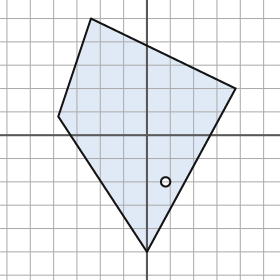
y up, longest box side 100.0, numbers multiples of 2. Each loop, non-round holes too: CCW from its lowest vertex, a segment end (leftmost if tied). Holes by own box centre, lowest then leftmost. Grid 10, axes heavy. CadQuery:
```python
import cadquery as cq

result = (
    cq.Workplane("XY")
    .moveTo(0.0, -50.0)
    .lineTo(38.0, 20.0)
    .lineTo(-24.0, 50.0)
    .lineTo(-38.0, 8.0)
    .close()
    .moveTo(8.0, -20.0)
    .circle(2.0)
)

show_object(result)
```